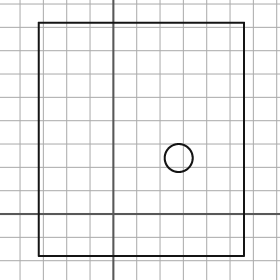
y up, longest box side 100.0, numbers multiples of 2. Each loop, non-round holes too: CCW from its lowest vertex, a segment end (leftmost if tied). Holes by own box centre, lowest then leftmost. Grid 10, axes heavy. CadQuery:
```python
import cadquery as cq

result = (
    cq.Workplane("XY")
    .moveTo(-32.0, -18.0)
    .lineTo(56.0, -18.0)
    .lineTo(56.0, 82.0)
    .lineTo(-32.0, 82.0)
    .close()
    .moveTo(28.0, 24.0)
    .circle(6.0)
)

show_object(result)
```